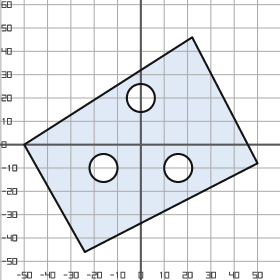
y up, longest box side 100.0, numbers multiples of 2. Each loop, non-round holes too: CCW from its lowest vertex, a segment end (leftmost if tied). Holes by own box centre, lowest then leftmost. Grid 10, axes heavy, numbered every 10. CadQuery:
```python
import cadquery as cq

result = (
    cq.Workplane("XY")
    .moveTo(-24.0, -46.0)
    .lineTo(50.0, -8.0)
    .lineTo(22.0, 46.0)
    .lineTo(-50.0, 0.0)
    .close()
    .moveTo(-16.0, -10.0)
    .circle(6.0)
    .moveTo(16.0, -10.0)
    .circle(6.0)
    .moveTo(0.0, 20.0)
    .circle(6.0)
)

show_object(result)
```